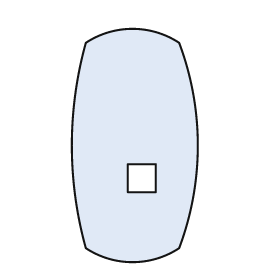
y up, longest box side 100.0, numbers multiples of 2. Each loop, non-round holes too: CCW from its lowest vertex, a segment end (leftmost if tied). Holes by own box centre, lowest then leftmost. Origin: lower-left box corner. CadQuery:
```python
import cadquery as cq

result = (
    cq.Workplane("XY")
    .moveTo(6.0, 6.0)
    .threePointArc((26.0, 0.0), (46.0, 6.0))
    .threePointArc((54.0, 50.0), (46.0, 94.0))
    .threePointArc((26.0, 100.0), (6.0, 94.0))
    .threePointArc((0.0, 50.0), (6.0, 6.0))
    .close()
    .moveTo(24.0, 30.0)
    .lineTo(36.0, 30.0)
    .lineTo(36.0, 42.0)
    .lineTo(24.0, 42.0)
    .close()
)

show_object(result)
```